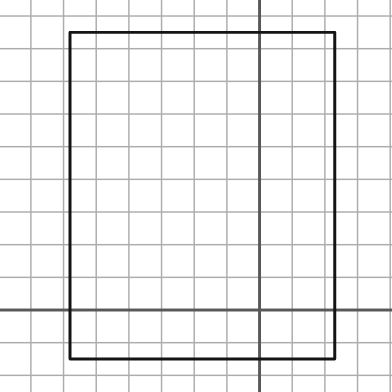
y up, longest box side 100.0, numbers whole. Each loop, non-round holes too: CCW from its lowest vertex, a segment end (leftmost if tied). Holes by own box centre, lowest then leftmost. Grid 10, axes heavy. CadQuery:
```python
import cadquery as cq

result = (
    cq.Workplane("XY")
    .moveTo(-58.0, -15.0)
    .lineTo(23.0, -15.0)
    .lineTo(23.0, 85.0)
    .lineTo(-58.0, 85.0)
    .close()
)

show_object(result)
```